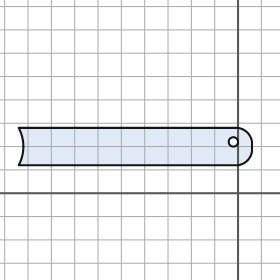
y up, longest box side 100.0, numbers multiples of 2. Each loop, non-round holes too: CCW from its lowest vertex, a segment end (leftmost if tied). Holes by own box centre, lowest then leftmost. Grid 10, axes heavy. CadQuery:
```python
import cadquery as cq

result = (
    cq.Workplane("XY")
    .moveTo(-94.0, 12.0)
    .lineTo(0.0, 12.0)
    .threePointArc((4.0, 14.0), (6.0, 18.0))
    .lineTo(6.0, 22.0)
    .threePointArc((4.0, 26.0), (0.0, 28.0))
    .lineTo(-94.0, 28.0)
    .threePointArc((-92.0, 20.0), (-94.0, 12.0))
    .close()
    .moveTo(-2.0, 22.0)
    .circle(2.0)
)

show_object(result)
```